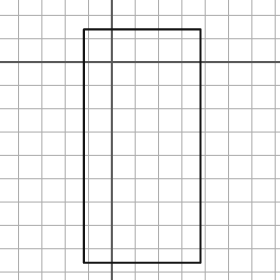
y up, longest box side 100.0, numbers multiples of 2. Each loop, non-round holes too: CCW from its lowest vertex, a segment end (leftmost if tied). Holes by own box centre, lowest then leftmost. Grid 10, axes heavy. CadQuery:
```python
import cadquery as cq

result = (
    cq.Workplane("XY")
    .moveTo(-12.0, -86.0)
    .lineTo(38.0, -86.0)
    .lineTo(38.0, 14.0)
    .lineTo(-12.0, 14.0)
    .close()
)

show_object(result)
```